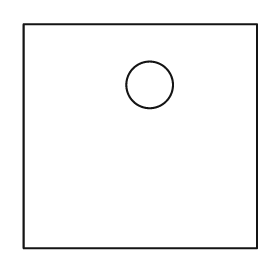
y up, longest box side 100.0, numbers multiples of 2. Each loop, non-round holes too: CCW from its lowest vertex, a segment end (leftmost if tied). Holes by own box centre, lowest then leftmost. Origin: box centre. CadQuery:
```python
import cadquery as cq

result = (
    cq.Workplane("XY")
    .moveTo(-50.0, -48.0)
    .lineTo(50.0, -48.0)
    .lineTo(50.0, 48.0)
    .lineTo(-50.0, 48.0)
    .close()
    .moveTo(4.0, 22.0)
    .circle(10.0)
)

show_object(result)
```